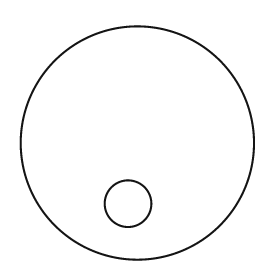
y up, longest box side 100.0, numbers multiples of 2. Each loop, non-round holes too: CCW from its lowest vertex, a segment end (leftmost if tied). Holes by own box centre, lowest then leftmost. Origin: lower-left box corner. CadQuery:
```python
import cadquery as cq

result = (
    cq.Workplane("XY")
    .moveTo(50.0, 50.0)
    .circle(50.0)
    .moveTo(46.0, 24.0)
    .circle(10.0)
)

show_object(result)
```